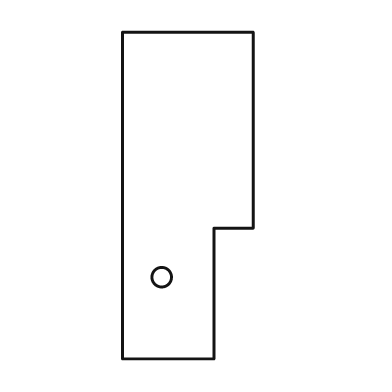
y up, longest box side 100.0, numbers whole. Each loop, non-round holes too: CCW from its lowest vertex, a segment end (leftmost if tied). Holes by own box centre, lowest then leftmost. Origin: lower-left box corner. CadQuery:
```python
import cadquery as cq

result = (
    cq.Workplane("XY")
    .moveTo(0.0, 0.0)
    .lineTo(28.0, 0.0)
    .lineTo(28.0, 40.0)
    .lineTo(40.0, 40.0)
    .lineTo(40.0, 100.0)
    .lineTo(0.0, 100.0)
    .close()
    .moveTo(12.0, 25.0)
    .circle(3.0)
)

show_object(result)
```